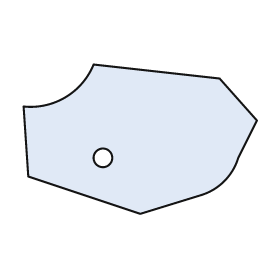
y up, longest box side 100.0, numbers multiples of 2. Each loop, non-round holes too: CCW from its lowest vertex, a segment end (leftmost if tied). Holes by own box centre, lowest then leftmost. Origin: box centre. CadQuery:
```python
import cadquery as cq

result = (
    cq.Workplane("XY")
    .moveTo(0.0, -32.0)
    .lineTo(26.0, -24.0)
    .threePointArc((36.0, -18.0), (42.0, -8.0))
    .lineTo(50.0, 8.0)
    .lineTo(34.0, 26.0)
    .lineTo(-20.0, 32.0)
    .threePointArc((-32.0, 18.0), (-50.0, 14.0))
    .lineTo(-48.0, -16.0)
    .close()
    .moveTo(-16.0, -8.0)
    .circle(4.0)
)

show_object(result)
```